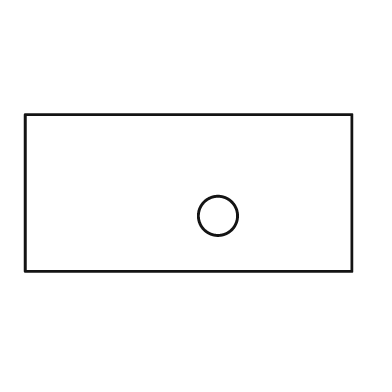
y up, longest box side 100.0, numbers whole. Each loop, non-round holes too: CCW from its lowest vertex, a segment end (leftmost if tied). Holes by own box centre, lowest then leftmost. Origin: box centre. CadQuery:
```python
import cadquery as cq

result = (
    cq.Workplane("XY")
    .moveTo(-50.0, -24.0)
    .lineTo(50.0, -24.0)
    .lineTo(50.0, 24.0)
    .lineTo(-50.0, 24.0)
    .close()
    .moveTo(9.0, -7.0)
    .circle(6.0)
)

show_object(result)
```